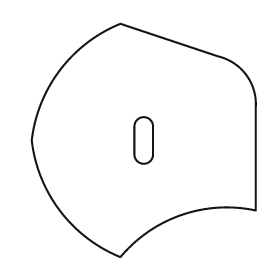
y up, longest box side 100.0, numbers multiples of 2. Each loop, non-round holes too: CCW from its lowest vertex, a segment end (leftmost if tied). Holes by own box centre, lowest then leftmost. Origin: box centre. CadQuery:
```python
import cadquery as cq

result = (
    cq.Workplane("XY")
    .moveTo(-10.0, -50.0)
    .threePointArc((16.0, -32.0), (48.0, -30.0))
    .lineTo(48.0, 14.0)
    .threePointArc((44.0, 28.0), (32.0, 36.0))
    .lineTo(-10.0, 50.0)
    .threePointArc((-36.0, 30.0), (-48.0, 0.0))
    .threePointArc((-36.0, -30.0), (-10.0, -50.0))
    .close()
    .moveTo(-4.0, -6.0)
    .threePointArc((0.0, -10.0), (4.0, -6.0))
    .lineTo(4.0, 6.0)
    .threePointArc((0.0, 10.0), (-4.0, 6.0))
    .close()
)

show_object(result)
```